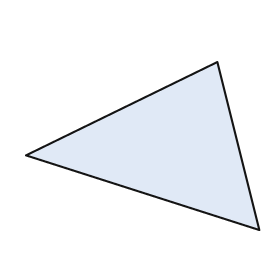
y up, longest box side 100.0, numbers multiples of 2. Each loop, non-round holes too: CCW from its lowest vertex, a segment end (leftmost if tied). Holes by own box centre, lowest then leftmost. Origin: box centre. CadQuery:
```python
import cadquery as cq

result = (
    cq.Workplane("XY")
    .moveTo(50.0, -36.0)
    .lineTo(32.0, 36.0)
    .lineTo(-50.0, -4.0)
    .close()
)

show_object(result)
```